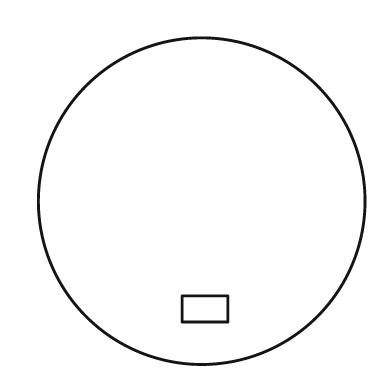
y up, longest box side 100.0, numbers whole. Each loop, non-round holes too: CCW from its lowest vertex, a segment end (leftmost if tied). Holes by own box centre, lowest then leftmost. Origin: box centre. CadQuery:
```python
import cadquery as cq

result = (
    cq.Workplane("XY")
    .moveTo(0.0, 0.0)
    .circle(50.0)
    .moveTo(-6.0, -37.0)
    .lineTo(8.0, -37.0)
    .lineTo(8.0, -29.0)
    .lineTo(-6.0, -29.0)
    .close()
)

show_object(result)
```